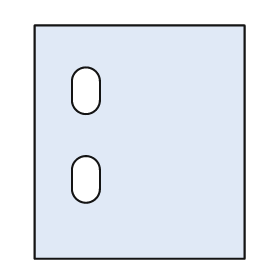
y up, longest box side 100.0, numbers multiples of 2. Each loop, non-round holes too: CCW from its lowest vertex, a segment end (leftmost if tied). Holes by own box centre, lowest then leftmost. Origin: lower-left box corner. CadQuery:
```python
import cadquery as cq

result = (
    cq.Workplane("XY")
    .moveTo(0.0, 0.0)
    .lineTo(90.0, 0.0)
    .lineTo(90.0, 100.0)
    .lineTo(0.0, 100.0)
    .close()
    .moveTo(16.0, 30.0)
    .threePointArc((22.0, 24.0), (28.0, 30.0))
    .lineTo(28.0, 38.0)
    .threePointArc((22.0, 44.0), (16.0, 38.0))
    .close()
    .moveTo(16.0, 68.0)
    .threePointArc((22.0, 62.0), (28.0, 68.0))
    .lineTo(28.0, 76.0)
    .threePointArc((22.0, 82.0), (16.0, 76.0))
    .close()
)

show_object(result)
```